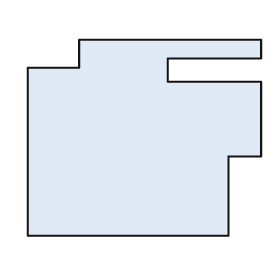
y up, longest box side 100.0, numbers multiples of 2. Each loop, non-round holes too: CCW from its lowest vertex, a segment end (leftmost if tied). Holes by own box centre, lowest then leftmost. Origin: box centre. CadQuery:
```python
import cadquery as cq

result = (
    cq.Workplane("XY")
    .moveTo(-50.0, -42.0)
    .lineTo(36.0, -42.0)
    .lineTo(36.0, -8.0)
    .lineTo(50.0, -8.0)
    .lineTo(50.0, 24.0)
    .lineTo(10.0, 24.0)
    .lineTo(10.0, 34.0)
    .lineTo(50.0, 34.0)
    .lineTo(50.0, 42.0)
    .lineTo(-28.0, 42.0)
    .lineTo(-28.0, 30.0)
    .lineTo(-50.0, 30.0)
    .close()
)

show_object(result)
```